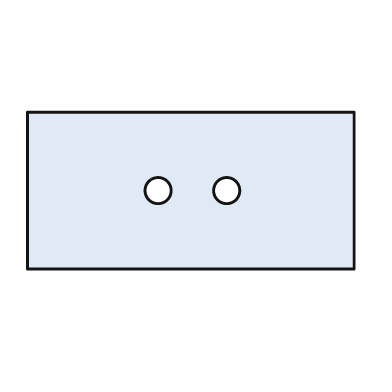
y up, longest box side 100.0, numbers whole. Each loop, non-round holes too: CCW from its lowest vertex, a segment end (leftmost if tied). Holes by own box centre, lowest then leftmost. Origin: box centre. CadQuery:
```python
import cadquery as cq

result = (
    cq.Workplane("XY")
    .moveTo(-50.0, -24.0)
    .lineTo(50.0, -24.0)
    .lineTo(50.0, 24.0)
    .lineTo(-50.0, 24.0)
    .close()
    .moveTo(-10.0, 0.0)
    .circle(4.0)
    .moveTo(11.0, 0.0)
    .circle(4.0)
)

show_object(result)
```